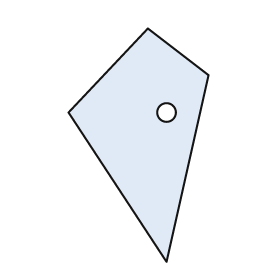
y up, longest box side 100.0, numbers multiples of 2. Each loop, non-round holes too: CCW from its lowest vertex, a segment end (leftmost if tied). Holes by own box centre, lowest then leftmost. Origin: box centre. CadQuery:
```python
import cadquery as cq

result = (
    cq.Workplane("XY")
    .moveTo(12.0, -50.0)
    .lineTo(30.0, 30.0)
    .lineTo(4.0, 50.0)
    .lineTo(-30.0, 14.0)
    .close()
    .moveTo(12.0, 14.0)
    .circle(4.0)
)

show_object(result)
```